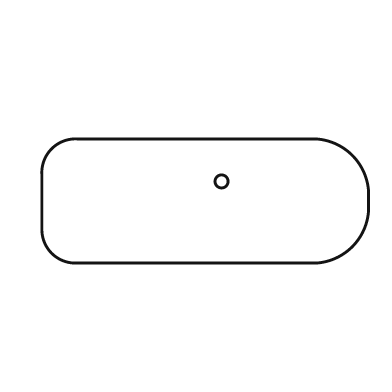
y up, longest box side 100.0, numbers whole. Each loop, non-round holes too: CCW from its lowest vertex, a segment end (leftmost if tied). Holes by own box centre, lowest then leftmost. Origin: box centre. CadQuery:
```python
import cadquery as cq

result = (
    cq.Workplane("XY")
    .moveTo(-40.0, -19.0)
    .lineTo(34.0, -19.0)
    .threePointArc((45.0, -14.0), (50.0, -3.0))
    .lineTo(50.0, 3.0)
    .threePointArc((45.0, 14.0), (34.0, 19.0))
    .lineTo(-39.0, 19.0)
    .threePointArc((-47.0, 16.0), (-50.0, 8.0))
    .lineTo(-50.0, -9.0)
    .threePointArc((-47.0, -16.0), (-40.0, -19.0))
    .close()
    .moveTo(5.0, 6.0)
    .circle(2.0)
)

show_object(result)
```